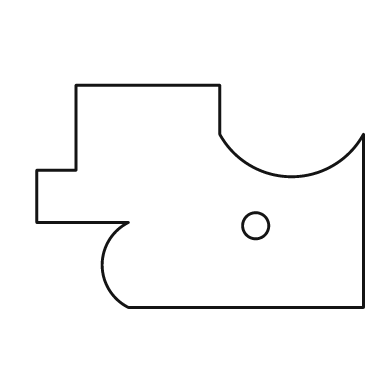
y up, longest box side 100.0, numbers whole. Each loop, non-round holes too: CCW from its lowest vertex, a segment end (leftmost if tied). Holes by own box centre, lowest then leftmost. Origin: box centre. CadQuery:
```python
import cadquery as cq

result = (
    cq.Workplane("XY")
    .moveTo(-22.0, -34.0)
    .lineTo(50.0, -34.0)
    .lineTo(50.0, 19.0)
    .threePointArc((28.0, 6.0), (6.0, 19.0))
    .lineTo(6.0, 34.0)
    .lineTo(-38.0, 34.0)
    .lineTo(-38.0, 8.0)
    .lineTo(-50.0, 8.0)
    .lineTo(-50.0, -8.0)
    .lineTo(-22.0, -8.0)
    .threePointArc((-30.0, -21.0), (-22.0, -34.0))
    .close()
    .moveTo(17.0, -9.0)
    .circle(4.0)
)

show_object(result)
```